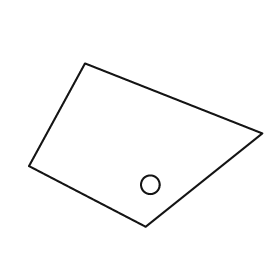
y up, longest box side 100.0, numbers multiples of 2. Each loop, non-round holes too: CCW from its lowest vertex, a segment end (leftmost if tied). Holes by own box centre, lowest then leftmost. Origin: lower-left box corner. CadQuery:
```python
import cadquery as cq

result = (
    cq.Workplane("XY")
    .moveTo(50.0, 0.0)
    .lineTo(100.0, 40.0)
    .lineTo(24.0, 70.0)
    .lineTo(0.0, 26.0)
    .close()
    .moveTo(52.0, 18.0)
    .circle(4.0)
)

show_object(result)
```